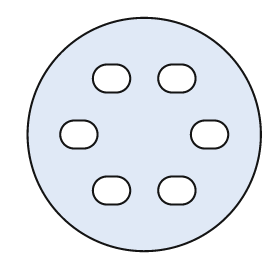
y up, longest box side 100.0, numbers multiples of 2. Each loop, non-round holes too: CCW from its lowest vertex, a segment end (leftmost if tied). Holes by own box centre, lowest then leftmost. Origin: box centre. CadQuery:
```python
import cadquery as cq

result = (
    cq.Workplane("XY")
    .moveTo(0.0, 0.0)
    .circle(50.0)
    .moveTo(-16.0, -30.0)
    .lineTo(-12.0, -30.0)
    .threePointArc((-6.0, -24.0), (-12.0, -18.0))
    .lineTo(-16.0, -18.0)
    .threePointArc((-22.0, -24.0), (-16.0, -30.0))
    .close()
    .moveTo(12.0, -30.0)
    .lineTo(16.0, -30.0)
    .threePointArc((22.0, -24.0), (16.0, -18.0))
    .lineTo(12.0, -18.0)
    .threePointArc((6.0, -24.0), (12.0, -30.0))
    .close()
    .moveTo(-30.0, -6.0)
    .lineTo(-26.0, -6.0)
    .threePointArc((-20.0, 0.0), (-26.0, 6.0))
    .lineTo(-30.0, 6.0)
    .threePointArc((-36.0, 0.0), (-30.0, -6.0))
    .close()
    .moveTo(26.0, -6.0)
    .lineTo(30.0, -6.0)
    .threePointArc((36.0, 0.0), (30.0, 6.0))
    .lineTo(26.0, 6.0)
    .threePointArc((20.0, 0.0), (26.0, -6.0))
    .close()
    .moveTo(-16.0, 18.0)
    .lineTo(-12.0, 18.0)
    .threePointArc((-6.0, 24.0), (-12.0, 30.0))
    .lineTo(-16.0, 30.0)
    .threePointArc((-22.0, 24.0), (-16.0, 18.0))
    .close()
    .moveTo(12.0, 18.0)
    .lineTo(16.0, 18.0)
    .threePointArc((22.0, 24.0), (16.0, 30.0))
    .lineTo(12.0, 30.0)
    .threePointArc((6.0, 24.0), (12.0, 18.0))
    .close()
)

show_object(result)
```